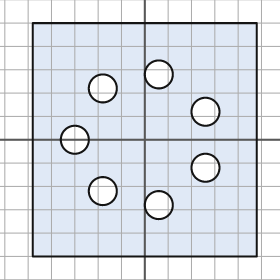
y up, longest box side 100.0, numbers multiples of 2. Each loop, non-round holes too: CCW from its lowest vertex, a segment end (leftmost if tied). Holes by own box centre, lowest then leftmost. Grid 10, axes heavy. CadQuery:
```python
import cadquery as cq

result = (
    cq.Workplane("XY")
    .moveTo(-48.0, -50.0)
    .lineTo(48.0, -50.0)
    .lineTo(48.0, 50.0)
    .lineTo(-48.0, 50.0)
    .close()
    .moveTo(6.0, -28.0)
    .circle(6.0)
    .moveTo(-18.0, -22.0)
    .circle(6.0)
    .moveTo(26.0, -12.0)
    .circle(6.0)
    .moveTo(-30.0, 0.0)
    .circle(6.0)
    .moveTo(26.0, 12.0)
    .circle(6.0)
    .moveTo(-18.0, 22.0)
    .circle(6.0)
    .moveTo(6.0, 28.0)
    .circle(6.0)
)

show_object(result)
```